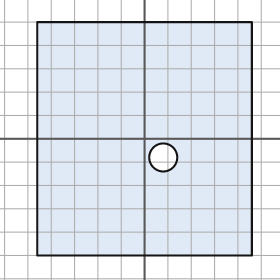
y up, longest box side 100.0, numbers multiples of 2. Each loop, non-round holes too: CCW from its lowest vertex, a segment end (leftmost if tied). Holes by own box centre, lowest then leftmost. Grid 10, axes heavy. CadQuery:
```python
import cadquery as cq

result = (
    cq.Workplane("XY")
    .moveTo(-46.0, -50.0)
    .lineTo(46.0, -50.0)
    .lineTo(46.0, 50.0)
    .lineTo(-46.0, 50.0)
    .close()
    .moveTo(8.0, -8.0)
    .circle(6.0)
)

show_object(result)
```